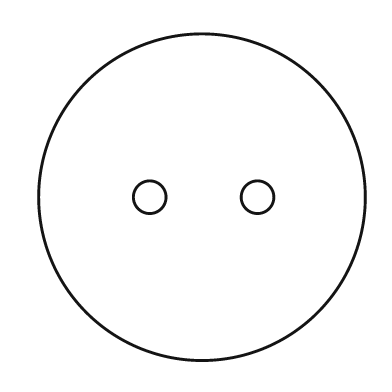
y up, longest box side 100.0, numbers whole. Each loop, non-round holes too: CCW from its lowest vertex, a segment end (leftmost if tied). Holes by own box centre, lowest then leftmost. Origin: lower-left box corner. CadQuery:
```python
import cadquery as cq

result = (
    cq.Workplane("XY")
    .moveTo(50.0, 50.0)
    .circle(50.0)
    .moveTo(34.0, 50.0)
    .circle(5.0)
    .moveTo(67.0, 50.0)
    .circle(5.0)
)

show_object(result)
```